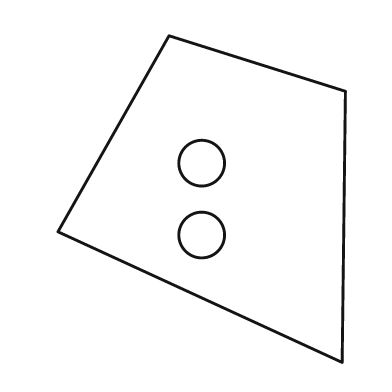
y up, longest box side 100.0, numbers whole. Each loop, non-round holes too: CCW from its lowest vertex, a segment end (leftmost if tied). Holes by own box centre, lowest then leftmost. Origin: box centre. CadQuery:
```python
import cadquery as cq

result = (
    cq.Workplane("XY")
    .moveTo(43.0, -50.0)
    .lineTo(44.0, 33.0)
    .lineTo(-10.0, 50.0)
    .lineTo(-44.0, -10.0)
    .close()
    .moveTo(0.0, -11.0)
    .circle(7.0)
    .moveTo(0.0, 11.0)
    .circle(7.0)
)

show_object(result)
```